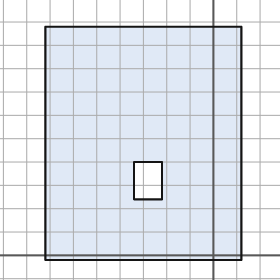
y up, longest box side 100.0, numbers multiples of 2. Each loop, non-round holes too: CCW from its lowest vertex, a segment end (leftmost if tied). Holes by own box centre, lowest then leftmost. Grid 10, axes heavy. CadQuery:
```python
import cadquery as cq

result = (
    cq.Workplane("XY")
    .moveTo(-72.0, -2.0)
    .lineTo(12.0, -2.0)
    .lineTo(12.0, 98.0)
    .lineTo(-72.0, 98.0)
    .close()
    .moveTo(-34.0, 24.0)
    .lineTo(-22.0, 24.0)
    .lineTo(-22.0, 40.0)
    .lineTo(-34.0, 40.0)
    .close()
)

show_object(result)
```